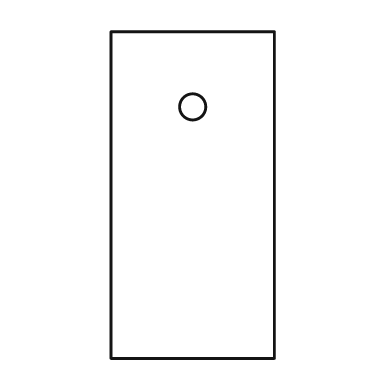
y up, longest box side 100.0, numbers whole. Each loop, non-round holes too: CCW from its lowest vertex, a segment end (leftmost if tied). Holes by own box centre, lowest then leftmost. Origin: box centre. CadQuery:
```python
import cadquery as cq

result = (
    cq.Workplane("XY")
    .moveTo(-25.0, -50.0)
    .lineTo(25.0, -50.0)
    .lineTo(25.0, 50.0)
    .lineTo(-25.0, 50.0)
    .close()
    .moveTo(0.0, 27.0)
    .circle(4.0)
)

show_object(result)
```